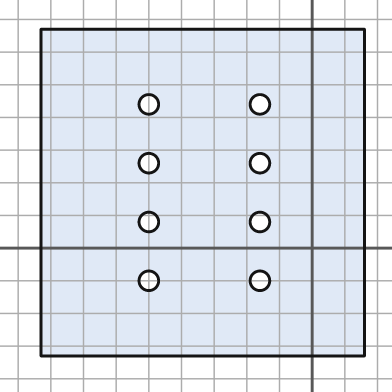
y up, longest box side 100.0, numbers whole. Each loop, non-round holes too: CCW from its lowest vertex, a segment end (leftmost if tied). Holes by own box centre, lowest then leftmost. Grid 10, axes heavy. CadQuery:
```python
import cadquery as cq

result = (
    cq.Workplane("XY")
    .moveTo(-83.0, -33.0)
    .lineTo(16.0, -33.0)
    .lineTo(16.0, 67.0)
    .lineTo(-83.0, 67.0)
    .close()
    .moveTo(-50.0, -10.0)
    .circle(3.0)
    .moveTo(-16.0, -10.0)
    .circle(3.0)
    .moveTo(-50.0, 8.0)
    .circle(3.0)
    .moveTo(-16.0, 8.0)
    .circle(3.0)
    .moveTo(-50.0, 26.0)
    .circle(3.0)
    .moveTo(-16.0, 26.0)
    .circle(3.0)
    .moveTo(-50.0, 44.0)
    .circle(3.0)
    .moveTo(-16.0, 44.0)
    .circle(3.0)
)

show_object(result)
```